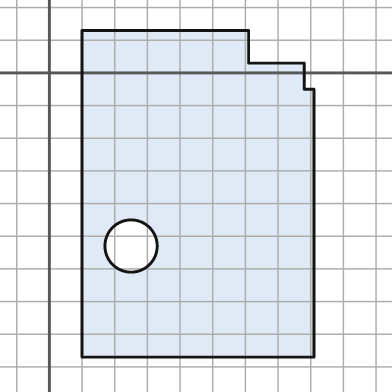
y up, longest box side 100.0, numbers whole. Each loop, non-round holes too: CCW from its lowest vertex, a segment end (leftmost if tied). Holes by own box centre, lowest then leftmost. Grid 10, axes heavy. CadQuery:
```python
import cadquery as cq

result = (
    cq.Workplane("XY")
    .moveTo(10.0, -87.0)
    .lineTo(81.0, -87.0)
    .lineTo(81.0, -5.0)
    .lineTo(78.0, -5.0)
    .lineTo(78.0, 3.0)
    .lineTo(61.0, 3.0)
    .lineTo(61.0, 13.0)
    .lineTo(10.0, 13.0)
    .close()
    .moveTo(25.0, -53.0)
    .circle(8.0)
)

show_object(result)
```